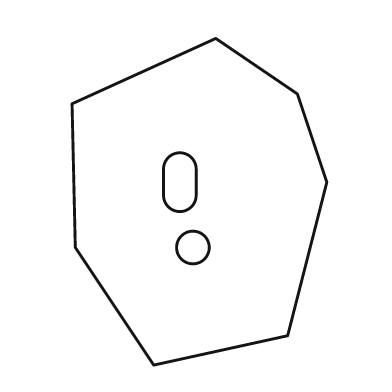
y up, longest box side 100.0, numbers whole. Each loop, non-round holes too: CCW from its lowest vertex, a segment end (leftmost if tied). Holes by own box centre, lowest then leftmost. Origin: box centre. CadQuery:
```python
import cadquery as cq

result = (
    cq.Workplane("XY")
    .moveTo(-14.0, -50.0)
    .lineTo(27.0, -41.0)
    .lineTo(39.0, 6.0)
    .lineTo(30.0, 33.0)
    .lineTo(5.0, 50.0)
    .lineTo(-39.0, 30.0)
    .lineTo(-38.0, -14.0)
    .close()
    .moveTo(-2.0, -14.0)
    .circle(5.0)
    .moveTo(-11.0, 2.0)
    .threePointArc((-6.0, -3.0), (-1.0, 2.0))
    .lineTo(-1.0, 10.0)
    .threePointArc((-6.0, 15.0), (-11.0, 10.0))
    .close()
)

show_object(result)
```